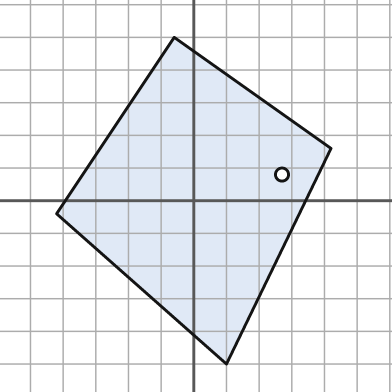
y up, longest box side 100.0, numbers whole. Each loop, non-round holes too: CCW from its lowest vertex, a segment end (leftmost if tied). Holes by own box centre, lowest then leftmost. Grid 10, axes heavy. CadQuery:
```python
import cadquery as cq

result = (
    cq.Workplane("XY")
    .moveTo(10.0, -50.0)
    .lineTo(42.0, 16.0)
    .lineTo(-6.0, 50.0)
    .lineTo(-42.0, -4.0)
    .close()
    .moveTo(27.0, 8.0)
    .circle(2.0)
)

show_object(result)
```